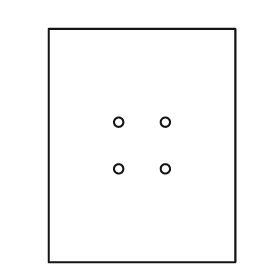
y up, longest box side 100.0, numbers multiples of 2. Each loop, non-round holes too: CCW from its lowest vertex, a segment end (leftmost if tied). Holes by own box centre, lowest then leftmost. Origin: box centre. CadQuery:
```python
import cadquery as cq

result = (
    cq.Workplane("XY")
    .moveTo(-40.0, -50.0)
    .lineTo(40.0, -50.0)
    .lineTo(40.0, 50.0)
    .lineTo(-40.0, 50.0)
    .close()
    .moveTo(-10.0, -10.0)
    .circle(2.0)
    .moveTo(10.0, -10.0)
    .circle(2.0)
    .moveTo(-10.0, 10.0)
    .circle(2.0)
    .moveTo(10.0, 10.0)
    .circle(2.0)
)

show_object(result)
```